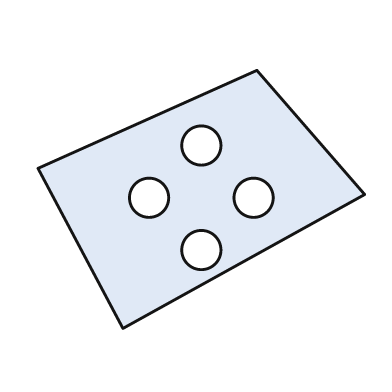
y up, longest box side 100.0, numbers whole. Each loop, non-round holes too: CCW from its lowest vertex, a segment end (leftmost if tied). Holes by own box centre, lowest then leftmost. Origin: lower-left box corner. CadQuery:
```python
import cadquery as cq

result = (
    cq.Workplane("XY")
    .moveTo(26.0, 0.0)
    .lineTo(100.0, 41.0)
    .lineTo(67.0, 79.0)
    .lineTo(0.0, 49.0)
    .close()
    .moveTo(50.0, 24.0)
    .circle(6.0)
    .moveTo(34.0, 40.0)
    .circle(6.0)
    .moveTo(66.0, 40.0)
    .circle(6.0)
    .moveTo(50.0, 56.0)
    .circle(6.0)
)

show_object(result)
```